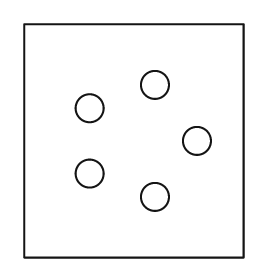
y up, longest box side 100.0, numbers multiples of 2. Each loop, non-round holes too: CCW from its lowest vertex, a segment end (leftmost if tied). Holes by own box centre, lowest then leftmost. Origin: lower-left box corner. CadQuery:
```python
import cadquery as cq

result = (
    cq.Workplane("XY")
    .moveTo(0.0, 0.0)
    .lineTo(94.0, 0.0)
    .lineTo(94.0, 100.0)
    .lineTo(0.0, 100.0)
    .close()
    .moveTo(56.0, 26.0)
    .circle(6.0)
    .moveTo(28.0, 36.0)
    .circle(6.0)
    .moveTo(74.0, 50.0)
    .circle(6.0)
    .moveTo(28.0, 64.0)
    .circle(6.0)
    .moveTo(56.0, 74.0)
    .circle(6.0)
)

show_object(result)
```